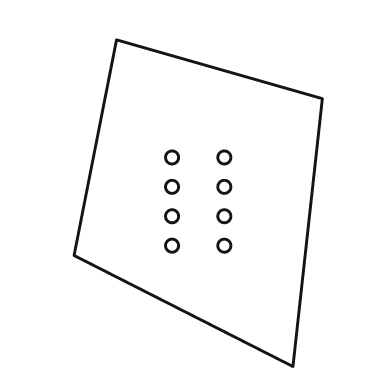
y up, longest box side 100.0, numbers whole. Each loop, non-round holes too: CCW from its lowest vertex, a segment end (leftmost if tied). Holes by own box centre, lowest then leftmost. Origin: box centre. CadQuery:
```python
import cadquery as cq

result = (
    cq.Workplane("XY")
    .moveTo(29.0, -50.0)
    .lineTo(38.0, 32.0)
    .lineTo(-25.0, 50.0)
    .lineTo(-38.0, -16.0)
    .close()
    .moveTo(-8.0, -13.0)
    .circle(2.0)
    .moveTo(8.0, -13.0)
    .circle(2.0)
    .moveTo(-8.0, -4.0)
    .circle(2.0)
    .moveTo(8.0, -4.0)
    .circle(2.0)
    .moveTo(-8.0, 5.0)
    .circle(2.0)
    .moveTo(8.0, 5.0)
    .circle(2.0)
    .moveTo(-8.0, 14.0)
    .circle(2.0)
    .moveTo(8.0, 14.0)
    .circle(2.0)
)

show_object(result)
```